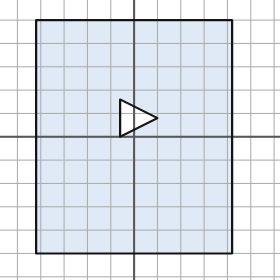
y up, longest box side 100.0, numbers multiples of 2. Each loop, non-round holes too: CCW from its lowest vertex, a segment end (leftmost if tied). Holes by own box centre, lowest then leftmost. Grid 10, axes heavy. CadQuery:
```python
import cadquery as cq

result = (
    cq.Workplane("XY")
    .moveTo(-42.0, -50.0)
    .lineTo(42.0, -50.0)
    .lineTo(42.0, 50.0)
    .lineTo(-42.0, 50.0)
    .close()
    .moveTo(-6.0, 0.0)
    .lineTo(10.0, 8.0)
    .lineTo(-6.0, 16.0)
    .close()
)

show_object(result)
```